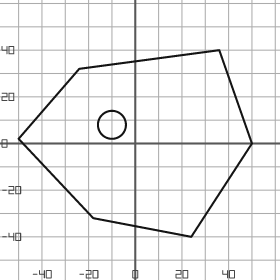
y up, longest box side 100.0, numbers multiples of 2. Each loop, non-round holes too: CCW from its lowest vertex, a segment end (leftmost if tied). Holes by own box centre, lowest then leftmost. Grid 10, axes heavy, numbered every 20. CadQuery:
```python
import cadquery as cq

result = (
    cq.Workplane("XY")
    .moveTo(24.0, -40.0)
    .lineTo(50.0, 0.0)
    .lineTo(36.0, 40.0)
    .lineTo(-24.0, 32.0)
    .lineTo(-50.0, 2.0)
    .lineTo(-18.0, -32.0)
    .close()
    .moveTo(-10.0, 8.0)
    .circle(6.0)
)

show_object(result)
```